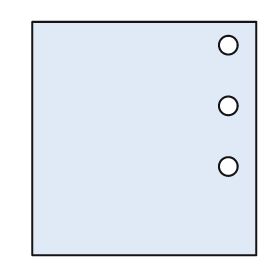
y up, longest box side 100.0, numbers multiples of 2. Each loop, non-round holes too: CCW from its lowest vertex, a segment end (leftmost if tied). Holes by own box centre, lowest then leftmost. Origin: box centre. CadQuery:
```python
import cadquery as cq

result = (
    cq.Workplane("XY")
    .moveTo(-48.0, -50.0)
    .lineTo(48.0, -50.0)
    .lineTo(48.0, 50.0)
    .lineTo(-48.0, 50.0)
    .close()
    .moveTo(36.0, -12.0)
    .circle(4.0)
    .moveTo(36.0, 14.0)
    .circle(4.0)
    .moveTo(36.0, 40.0)
    .circle(4.0)
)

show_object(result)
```